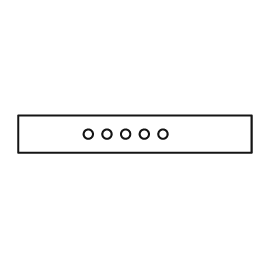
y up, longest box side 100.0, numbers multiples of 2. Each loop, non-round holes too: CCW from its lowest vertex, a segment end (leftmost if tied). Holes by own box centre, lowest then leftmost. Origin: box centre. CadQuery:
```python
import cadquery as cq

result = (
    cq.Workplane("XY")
    .moveTo(-50.0, -8.0)
    .lineTo(50.0, -8.0)
    .lineTo(50.0, 8.0)
    .lineTo(-50.0, 8.0)
    .close()
    .moveTo(-20.0, 0.0)
    .circle(2.0)
    .moveTo(-12.0, 0.0)
    .circle(2.0)
    .moveTo(-4.0, 0.0)
    .circle(2.0)
    .moveTo(4.0, 0.0)
    .circle(2.0)
    .moveTo(12.0, 0.0)
    .circle(2.0)
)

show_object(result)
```